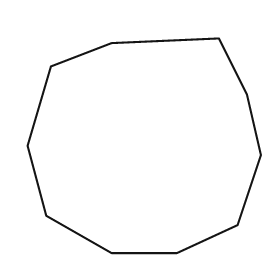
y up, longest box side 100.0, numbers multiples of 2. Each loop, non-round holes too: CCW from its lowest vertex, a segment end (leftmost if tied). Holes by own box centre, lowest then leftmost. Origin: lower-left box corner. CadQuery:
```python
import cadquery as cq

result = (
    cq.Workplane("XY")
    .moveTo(36.0, 0.0)
    .lineTo(64.0, 0.0)
    .lineTo(90.0, 12.0)
    .lineTo(100.0, 42.0)
    .lineTo(94.0, 68.0)
    .lineTo(82.0, 92.0)
    .lineTo(36.0, 90.0)
    .lineTo(10.0, 80.0)
    .lineTo(0.0, 46.0)
    .lineTo(8.0, 16.0)
    .close()
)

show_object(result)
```